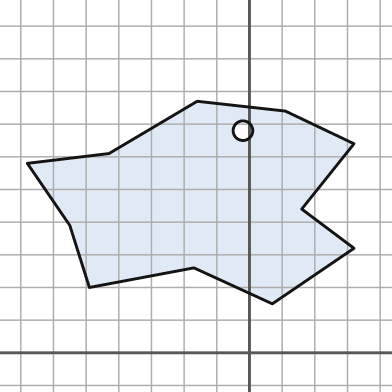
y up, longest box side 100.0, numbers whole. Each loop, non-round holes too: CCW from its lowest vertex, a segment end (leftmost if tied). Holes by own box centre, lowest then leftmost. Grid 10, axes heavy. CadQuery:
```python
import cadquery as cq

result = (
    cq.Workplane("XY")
    .moveTo(7.0, 15.0)
    .lineTo(32.0, 32.0)
    .lineTo(16.0, 44.0)
    .lineTo(32.0, 64.0)
    .lineTo(11.0, 74.0)
    .lineTo(-16.0, 77.0)
    .lineTo(-43.0, 61.0)
    .lineTo(-68.0, 58.0)
    .lineTo(-55.0, 39.0)
    .lineTo(-49.0, 20.0)
    .lineTo(-17.0, 26.0)
    .close()
    .moveTo(-2.0, 68.0)
    .circle(3.0)
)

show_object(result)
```